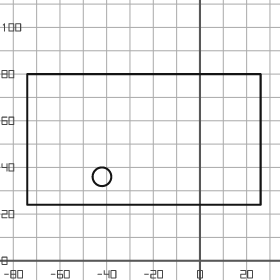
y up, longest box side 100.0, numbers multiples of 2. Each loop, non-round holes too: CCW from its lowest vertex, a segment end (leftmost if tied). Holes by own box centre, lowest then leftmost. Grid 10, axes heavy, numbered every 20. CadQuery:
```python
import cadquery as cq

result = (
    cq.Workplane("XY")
    .moveTo(-74.0, 24.0)
    .lineTo(26.0, 24.0)
    .lineTo(26.0, 80.0)
    .lineTo(-74.0, 80.0)
    .close()
    .moveTo(-42.0, 36.0)
    .circle(4.0)
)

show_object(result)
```